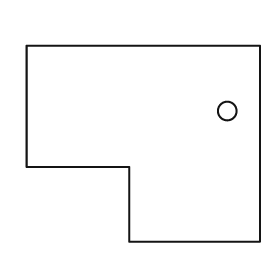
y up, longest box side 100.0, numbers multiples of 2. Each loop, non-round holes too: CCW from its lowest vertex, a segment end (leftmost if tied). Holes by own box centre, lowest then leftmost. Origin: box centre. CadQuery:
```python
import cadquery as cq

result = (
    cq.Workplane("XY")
    .moveTo(-6.0, -42.0)
    .lineTo(50.0, -42.0)
    .lineTo(50.0, 42.0)
    .lineTo(-50.0, 42.0)
    .lineTo(-50.0, -10.0)
    .lineTo(-6.0, -10.0)
    .close()
    .moveTo(36.0, 14.0)
    .circle(4.0)
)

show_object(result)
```